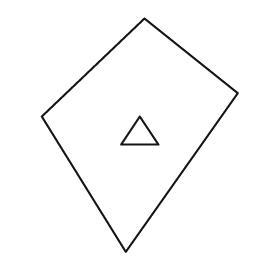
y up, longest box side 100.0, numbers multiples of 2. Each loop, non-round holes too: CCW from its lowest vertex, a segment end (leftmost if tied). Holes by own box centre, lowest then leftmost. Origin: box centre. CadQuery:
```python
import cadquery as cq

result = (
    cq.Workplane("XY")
    .moveTo(-6.0, -50.0)
    .lineTo(42.0, 18.0)
    .lineTo(2.0, 50.0)
    .lineTo(-42.0, 8.0)
    .close()
    .moveTo(-8.0, -4.0)
    .lineTo(8.0, -4.0)
    .lineTo(0.0, 8.0)
    .close()
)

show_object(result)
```